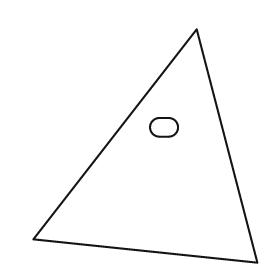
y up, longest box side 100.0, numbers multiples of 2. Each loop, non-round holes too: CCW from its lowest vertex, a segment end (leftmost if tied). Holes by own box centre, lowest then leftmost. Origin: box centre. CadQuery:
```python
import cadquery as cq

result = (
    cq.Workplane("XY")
    .moveTo(48.0, -50.0)
    .lineTo(22.0, 50.0)
    .lineTo(-48.0, -40.0)
    .close()
    .moveTo(6.0, 4.0)
    .lineTo(10.0, 4.0)
    .threePointArc((14.0, 8.0), (10.0, 12.0))
    .lineTo(6.0, 12.0)
    .threePointArc((2.0, 8.0), (6.0, 4.0))
    .close()
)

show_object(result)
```